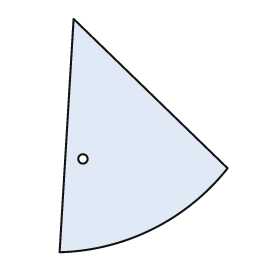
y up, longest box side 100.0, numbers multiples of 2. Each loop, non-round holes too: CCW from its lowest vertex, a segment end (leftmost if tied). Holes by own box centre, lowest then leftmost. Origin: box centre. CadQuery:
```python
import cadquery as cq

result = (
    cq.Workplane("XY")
    .moveTo(-36.0, -50.0)
    .threePointArc((4.0, -40.0), (36.0, -14.0))
    .lineTo(-30.0, 50.0)
    .close()
    .moveTo(-26.0, -10.0)
    .circle(2.0)
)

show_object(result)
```